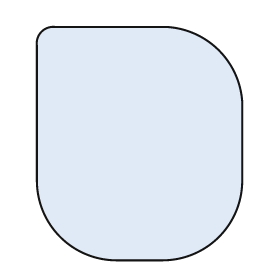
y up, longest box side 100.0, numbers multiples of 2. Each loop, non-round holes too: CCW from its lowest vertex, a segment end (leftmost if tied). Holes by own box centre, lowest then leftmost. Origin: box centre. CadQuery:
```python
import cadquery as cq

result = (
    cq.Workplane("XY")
    .moveTo(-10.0, -50.0)
    .lineTo(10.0, -50.0)
    .threePointArc((34.0, -40.0), (44.0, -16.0))
    .lineTo(44.0, 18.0)
    .threePointArc((34.0, 40.0), (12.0, 50.0))
    .lineTo(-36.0, 50.0)
    .threePointArc((-42.0, 48.0), (-44.0, 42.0))
    .lineTo(-44.0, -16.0)
    .threePointArc((-34.0, -40.0), (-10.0, -50.0))
    .close()
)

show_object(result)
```